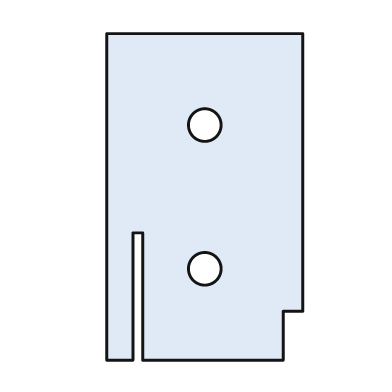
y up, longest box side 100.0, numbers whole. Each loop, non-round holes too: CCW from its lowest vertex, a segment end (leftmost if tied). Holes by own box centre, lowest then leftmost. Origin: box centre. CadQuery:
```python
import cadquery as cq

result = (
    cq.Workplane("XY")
    .moveTo(-30.0, -50.0)
    .lineTo(-22.0, -50.0)
    .lineTo(-22.0, -11.0)
    .lineTo(-19.0, -11.0)
    .lineTo(-19.0, -50.0)
    .lineTo(24.0, -50.0)
    .lineTo(24.0, -35.0)
    .lineTo(30.0, -35.0)
    .lineTo(30.0, 50.0)
    .lineTo(-30.0, 50.0)
    .close()
    .moveTo(0.0, -22.0)
    .circle(5.0)
    .moveTo(0.0, 22.0)
    .circle(5.0)
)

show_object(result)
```